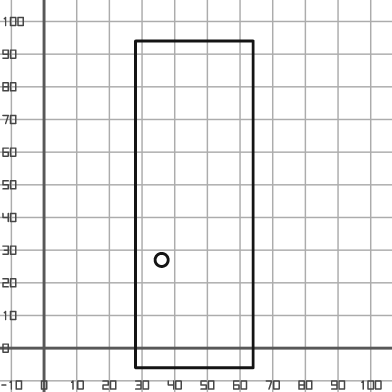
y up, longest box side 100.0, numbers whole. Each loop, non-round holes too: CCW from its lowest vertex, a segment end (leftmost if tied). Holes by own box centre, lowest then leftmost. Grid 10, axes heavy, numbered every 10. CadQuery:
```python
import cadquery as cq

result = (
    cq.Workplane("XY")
    .moveTo(28.0, -6.0)
    .lineTo(64.0, -6.0)
    .lineTo(64.0, 94.0)
    .lineTo(28.0, 94.0)
    .close()
    .moveTo(36.0, 27.0)
    .circle(2.0)
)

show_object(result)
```